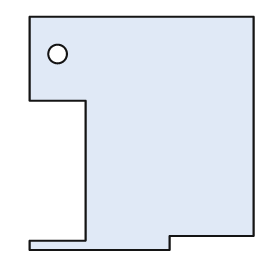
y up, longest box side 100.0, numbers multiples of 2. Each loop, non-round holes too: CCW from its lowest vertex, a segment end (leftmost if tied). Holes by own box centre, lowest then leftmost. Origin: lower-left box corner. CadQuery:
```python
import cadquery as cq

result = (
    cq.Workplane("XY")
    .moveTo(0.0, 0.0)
    .lineTo(60.0, 0.0)
    .lineTo(60.0, 6.0)
    .lineTo(96.0, 6.0)
    .lineTo(96.0, 100.0)
    .lineTo(0.0, 100.0)
    .lineTo(0.0, 64.0)
    .lineTo(24.0, 64.0)
    .lineTo(24.0, 4.0)
    .lineTo(0.0, 4.0)
    .close()
    .moveTo(12.0, 84.0)
    .circle(4.0)
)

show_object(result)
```